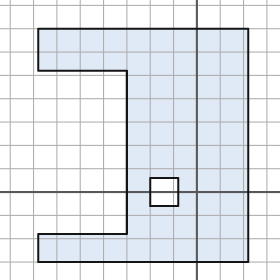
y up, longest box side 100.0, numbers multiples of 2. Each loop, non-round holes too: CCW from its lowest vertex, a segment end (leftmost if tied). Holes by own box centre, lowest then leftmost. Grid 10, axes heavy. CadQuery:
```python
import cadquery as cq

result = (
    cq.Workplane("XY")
    .moveTo(-68.0, -30.0)
    .lineTo(22.0, -30.0)
    .lineTo(22.0, 70.0)
    .lineTo(-68.0, 70.0)
    .lineTo(-68.0, 52.0)
    .lineTo(-30.0, 52.0)
    .lineTo(-30.0, -18.0)
    .lineTo(-68.0, -18.0)
    .close()
    .moveTo(-20.0, -6.0)
    .lineTo(-8.0, -6.0)
    .lineTo(-8.0, 6.0)
    .lineTo(-20.0, 6.0)
    .close()
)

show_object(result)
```